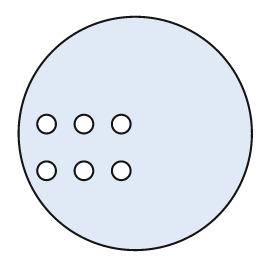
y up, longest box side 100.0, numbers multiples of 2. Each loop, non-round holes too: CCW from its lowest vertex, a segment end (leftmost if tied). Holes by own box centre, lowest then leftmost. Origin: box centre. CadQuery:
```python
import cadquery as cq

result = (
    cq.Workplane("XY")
    .moveTo(0.0, 0.0)
    .circle(50.0)
    .moveTo(-38.0, -16.0)
    .circle(4.0)
    .moveTo(-22.0, -16.0)
    .circle(4.0)
    .moveTo(-6.0, -16.0)
    .circle(4.0)
    .moveTo(-38.0, 4.0)
    .circle(4.0)
    .moveTo(-22.0, 4.0)
    .circle(4.0)
    .moveTo(-6.0, 4.0)
    .circle(4.0)
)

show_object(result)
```